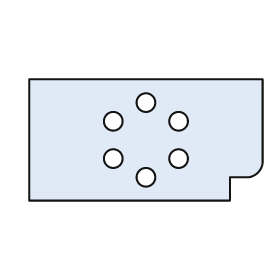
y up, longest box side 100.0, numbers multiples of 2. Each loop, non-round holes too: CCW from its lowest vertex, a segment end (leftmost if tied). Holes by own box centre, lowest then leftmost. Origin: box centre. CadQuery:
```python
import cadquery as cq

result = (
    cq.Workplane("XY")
    .moveTo(-50.0, -26.0)
    .lineTo(36.0, -26.0)
    .lineTo(36.0, -16.0)
    .lineTo(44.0, -16.0)
    .threePointArc((48.0, -14.0), (50.0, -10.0))
    .lineTo(50.0, 26.0)
    .lineTo(-50.0, 26.0)
    .close()
    .moveTo(0.0, -16.0)
    .circle(4.0)
    .moveTo(-14.0, -8.0)
    .circle(4.0)
    .moveTo(14.0, -8.0)
    .circle(4.0)
    .moveTo(-14.0, 8.0)
    .circle(4.0)
    .moveTo(14.0, 8.0)
    .circle(4.0)
    .moveTo(0.0, 16.0)
    .circle(4.0)
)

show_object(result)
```